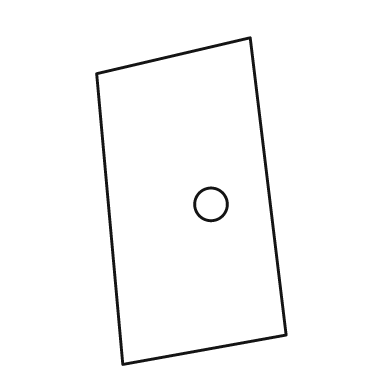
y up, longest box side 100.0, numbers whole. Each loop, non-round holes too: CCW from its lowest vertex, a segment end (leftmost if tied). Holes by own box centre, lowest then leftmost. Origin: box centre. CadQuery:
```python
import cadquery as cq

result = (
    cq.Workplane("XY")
    .moveTo(-21.0, -50.0)
    .lineTo(29.0, -41.0)
    .lineTo(18.0, 50.0)
    .lineTo(-29.0, 39.0)
    .close()
    .moveTo(6.0, -1.0)
    .circle(5.0)
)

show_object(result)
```